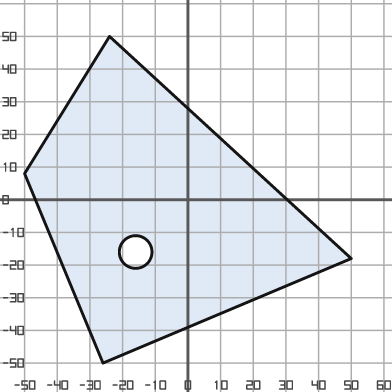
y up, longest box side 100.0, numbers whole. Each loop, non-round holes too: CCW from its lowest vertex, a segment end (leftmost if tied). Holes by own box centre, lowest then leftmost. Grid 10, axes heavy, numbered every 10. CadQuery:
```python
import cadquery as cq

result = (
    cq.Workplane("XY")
    .moveTo(-26.0, -50.0)
    .lineTo(50.0, -18.0)
    .lineTo(-24.0, 50.0)
    .lineTo(-50.0, 8.0)
    .close()
    .moveTo(-16.0, -16.0)
    .circle(5.0)
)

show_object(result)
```